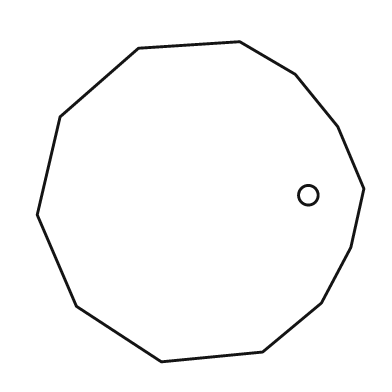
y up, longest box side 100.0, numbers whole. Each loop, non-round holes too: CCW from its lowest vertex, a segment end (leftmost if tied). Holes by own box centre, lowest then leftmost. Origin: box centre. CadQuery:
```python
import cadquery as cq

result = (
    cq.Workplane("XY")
    .moveTo(-12.0, -49.0)
    .lineTo(19.0, -46.0)
    .lineTo(37.0, -31.0)
    .lineTo(46.0, -14.0)
    .lineTo(50.0, 4.0)
    .lineTo(42.0, 23.0)
    .lineTo(29.0, 39.0)
    .lineTo(12.0, 49.0)
    .lineTo(-19.0, 47.0)
    .lineTo(-43.0, 26.0)
    .lineTo(-50.0, -4.0)
    .lineTo(-38.0, -32.0)
    .close()
    .moveTo(33.0, 2.0)
    .circle(3.0)
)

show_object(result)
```